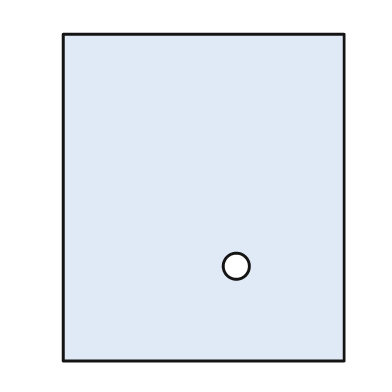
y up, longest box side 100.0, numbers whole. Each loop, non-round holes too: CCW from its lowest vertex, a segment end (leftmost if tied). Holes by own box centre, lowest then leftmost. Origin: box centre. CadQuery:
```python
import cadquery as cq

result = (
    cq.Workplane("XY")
    .moveTo(-43.0, -50.0)
    .lineTo(43.0, -50.0)
    .lineTo(43.0, 50.0)
    .lineTo(-43.0, 50.0)
    .close()
    .moveTo(10.0, -21.0)
    .circle(4.0)
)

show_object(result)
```